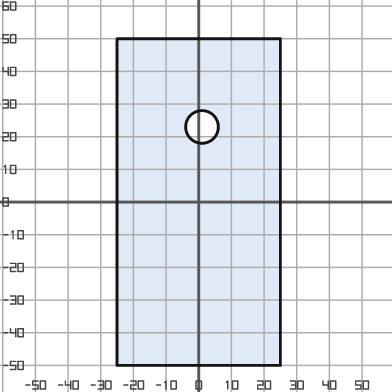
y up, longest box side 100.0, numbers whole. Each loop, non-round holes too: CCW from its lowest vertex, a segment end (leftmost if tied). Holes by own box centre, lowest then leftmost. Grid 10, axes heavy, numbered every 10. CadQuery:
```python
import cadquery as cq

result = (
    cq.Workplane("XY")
    .moveTo(-25.0, -50.0)
    .lineTo(25.0, -50.0)
    .lineTo(25.0, 50.0)
    .lineTo(-25.0, 50.0)
    .close()
    .moveTo(1.0, 23.0)
    .circle(5.0)
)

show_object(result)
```